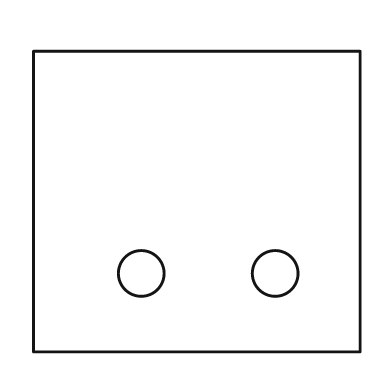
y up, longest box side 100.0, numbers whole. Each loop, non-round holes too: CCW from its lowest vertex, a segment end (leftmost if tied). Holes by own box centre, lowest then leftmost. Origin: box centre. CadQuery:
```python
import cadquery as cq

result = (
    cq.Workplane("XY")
    .moveTo(-50.0, -46.0)
    .lineTo(50.0, -46.0)
    .lineTo(50.0, 46.0)
    .lineTo(-50.0, 46.0)
    .close()
    .moveTo(-17.0, -22.0)
    .circle(7.0)
    .moveTo(24.0, -22.0)
    .circle(7.0)
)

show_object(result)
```